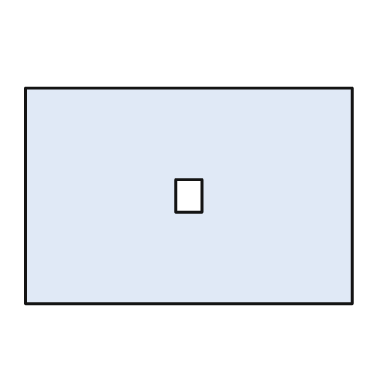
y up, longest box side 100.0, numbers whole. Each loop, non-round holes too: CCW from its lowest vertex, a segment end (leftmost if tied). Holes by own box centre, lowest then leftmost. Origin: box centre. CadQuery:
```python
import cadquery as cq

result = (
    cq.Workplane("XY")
    .moveTo(-50.0, -33.0)
    .lineTo(50.0, -33.0)
    .lineTo(50.0, 33.0)
    .lineTo(-50.0, 33.0)
    .close()
    .moveTo(-4.0, -5.0)
    .lineTo(4.0, -5.0)
    .lineTo(4.0, 5.0)
    .lineTo(-4.0, 5.0)
    .close()
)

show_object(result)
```